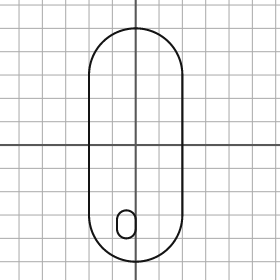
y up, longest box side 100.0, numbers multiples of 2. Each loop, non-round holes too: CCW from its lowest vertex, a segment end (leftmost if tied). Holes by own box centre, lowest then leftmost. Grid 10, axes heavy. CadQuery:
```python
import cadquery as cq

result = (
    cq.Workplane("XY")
    .moveTo(-20.0, -30.0)
    .threePointArc((0.0, -50.0), (20.0, -30.0))
    .lineTo(20.0, 30.0)
    .threePointArc((0.0, 50.0), (-20.0, 30.0))
    .close()
    .moveTo(-8.0, -36.0)
    .threePointArc((-4.0, -40.0), (0.0, -36.0))
    .lineTo(0.0, -32.0)
    .threePointArc((-4.0, -28.0), (-8.0, -32.0))
    .close()
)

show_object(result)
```